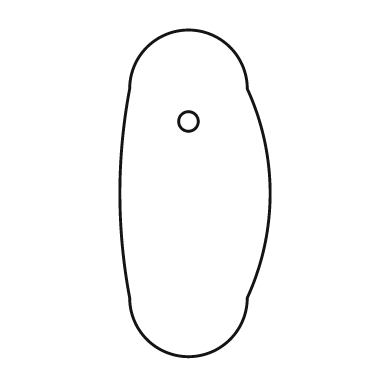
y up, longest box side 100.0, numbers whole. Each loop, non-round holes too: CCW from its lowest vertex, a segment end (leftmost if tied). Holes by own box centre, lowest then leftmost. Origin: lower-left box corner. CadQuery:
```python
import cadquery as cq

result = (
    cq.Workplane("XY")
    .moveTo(3.0, 18.0)
    .threePointArc((21.0, 0.0), (39.0, 18.0))
    .threePointArc((46.0, 50.0), (39.0, 82.0))
    .threePointArc((21.0, 100.0), (3.0, 82.0))
    .threePointArc((0.0, 50.0), (3.0, 18.0))
    .close()
    .moveTo(21.0, 72.0)
    .circle(3.0)
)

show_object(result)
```